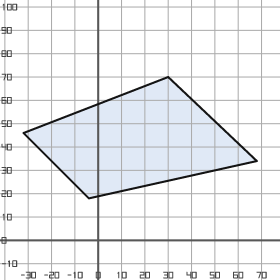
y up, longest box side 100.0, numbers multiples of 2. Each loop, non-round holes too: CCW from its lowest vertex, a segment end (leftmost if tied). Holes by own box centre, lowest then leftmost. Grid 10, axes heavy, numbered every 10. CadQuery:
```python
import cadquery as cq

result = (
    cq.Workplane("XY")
    .moveTo(-4.0, 18.0)
    .lineTo(68.0, 34.0)
    .lineTo(30.0, 70.0)
    .lineTo(-32.0, 46.0)
    .close()
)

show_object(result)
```